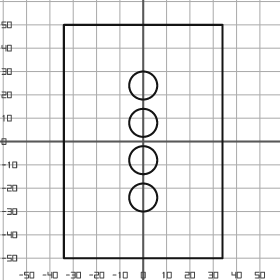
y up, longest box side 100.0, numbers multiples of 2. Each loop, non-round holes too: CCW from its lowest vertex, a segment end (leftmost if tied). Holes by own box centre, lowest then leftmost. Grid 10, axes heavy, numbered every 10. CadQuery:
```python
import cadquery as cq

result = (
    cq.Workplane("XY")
    .moveTo(-34.0, -50.0)
    .lineTo(34.0, -50.0)
    .lineTo(34.0, 50.0)
    .lineTo(-34.0, 50.0)
    .close()
    .moveTo(0.0, -24.0)
    .circle(6.0)
    .moveTo(0.0, -8.0)
    .circle(6.0)
    .moveTo(0.0, 8.0)
    .circle(6.0)
    .moveTo(0.0, 24.0)
    .circle(6.0)
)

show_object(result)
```